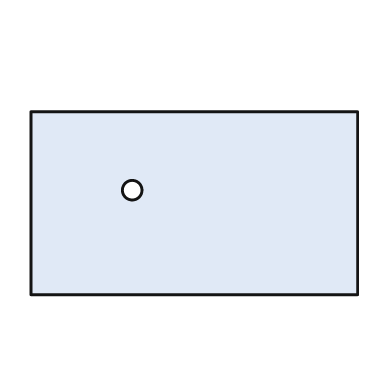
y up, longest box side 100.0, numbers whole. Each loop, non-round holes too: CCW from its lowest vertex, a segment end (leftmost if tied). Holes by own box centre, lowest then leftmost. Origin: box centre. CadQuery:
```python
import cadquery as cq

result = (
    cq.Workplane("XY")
    .moveTo(-50.0, -28.0)
    .lineTo(50.0, -28.0)
    .lineTo(50.0, 28.0)
    .lineTo(-50.0, 28.0)
    .close()
    .moveTo(-19.0, 4.0)
    .circle(3.0)
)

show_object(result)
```